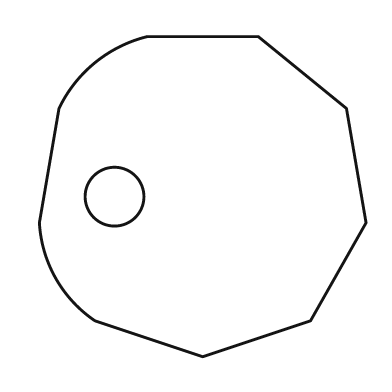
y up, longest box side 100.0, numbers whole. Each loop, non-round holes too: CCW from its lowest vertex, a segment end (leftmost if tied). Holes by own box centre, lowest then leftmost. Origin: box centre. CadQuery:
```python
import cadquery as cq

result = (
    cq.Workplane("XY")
    .moveTo(0.0, -49.0)
    .lineTo(33.0, -38.0)
    .lineTo(50.0, -8.0)
    .lineTo(44.0, 27.0)
    .lineTo(17.0, 49.0)
    .lineTo(-17.0, 49.0)
    .threePointArc((-33.0, 41.0), (-44.0, 27.0))
    .lineTo(-50.0, -8.0)
    .threePointArc((-45.0, -25.0), (-33.0, -38.0))
    .close()
    .moveTo(-27.0, 0.0)
    .circle(9.0)
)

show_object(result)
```